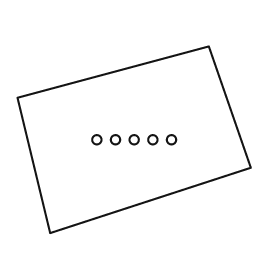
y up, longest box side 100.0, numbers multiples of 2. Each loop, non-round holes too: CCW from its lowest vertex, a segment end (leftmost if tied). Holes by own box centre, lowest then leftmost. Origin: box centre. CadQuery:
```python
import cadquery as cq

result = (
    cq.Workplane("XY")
    .moveTo(-36.0, -40.0)
    .lineTo(50.0, -12.0)
    .lineTo(32.0, 40.0)
    .lineTo(-50.0, 18.0)
    .close()
    .moveTo(-16.0, 0.0)
    .circle(2.0)
    .moveTo(-8.0, 0.0)
    .circle(2.0)
    .moveTo(0.0, 0.0)
    .circle(2.0)
    .moveTo(8.0, 0.0)
    .circle(2.0)
    .moveTo(16.0, 0.0)
    .circle(2.0)
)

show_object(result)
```